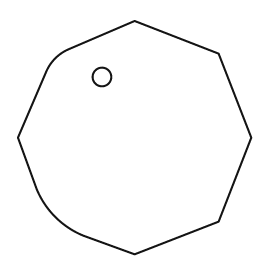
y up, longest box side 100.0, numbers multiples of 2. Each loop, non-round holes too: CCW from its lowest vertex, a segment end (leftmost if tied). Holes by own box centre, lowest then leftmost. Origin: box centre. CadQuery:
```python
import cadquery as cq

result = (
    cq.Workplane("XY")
    .moveTo(0.0, -50.0)
    .lineTo(36.0, -36.0)
    .lineTo(50.0, 0.0)
    .lineTo(36.0, 36.0)
    .lineTo(0.0, 50.0)
    .lineTo(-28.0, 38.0)
    .threePointArc((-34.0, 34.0), (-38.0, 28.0))
    .lineTo(-50.0, 0.0)
    .lineTo(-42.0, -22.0)
    .threePointArc((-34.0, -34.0), (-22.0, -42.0))
    .close()
    .moveTo(-14.0, 26.0)
    .circle(4.0)
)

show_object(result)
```